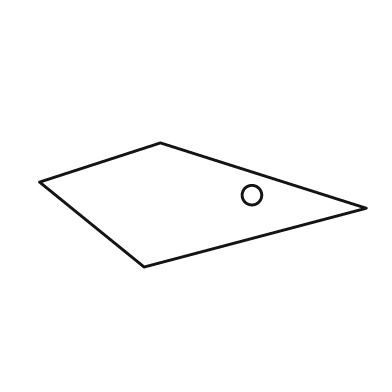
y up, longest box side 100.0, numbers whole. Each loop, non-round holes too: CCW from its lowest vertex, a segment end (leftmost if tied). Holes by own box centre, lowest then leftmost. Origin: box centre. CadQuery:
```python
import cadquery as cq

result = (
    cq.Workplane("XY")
    .moveTo(-18.0, -19.0)
    .lineTo(50.0, -1.0)
    .lineTo(-13.0, 19.0)
    .lineTo(-50.0, 7.0)
    .close()
    .moveTo(15.0, 3.0)
    .circle(3.0)
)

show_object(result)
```